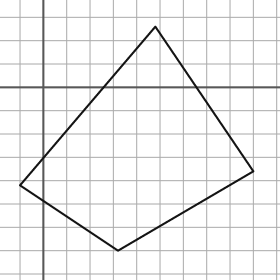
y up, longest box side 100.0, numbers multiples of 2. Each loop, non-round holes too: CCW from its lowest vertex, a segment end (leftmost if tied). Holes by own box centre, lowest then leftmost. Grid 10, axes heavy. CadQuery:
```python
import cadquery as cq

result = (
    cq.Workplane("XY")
    .moveTo(32.0, -70.0)
    .lineTo(90.0, -36.0)
    .lineTo(48.0, 26.0)
    .lineTo(-10.0, -42.0)
    .close()
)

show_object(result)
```